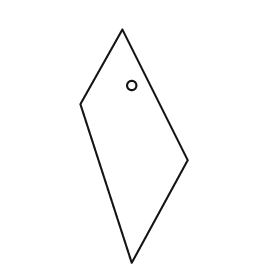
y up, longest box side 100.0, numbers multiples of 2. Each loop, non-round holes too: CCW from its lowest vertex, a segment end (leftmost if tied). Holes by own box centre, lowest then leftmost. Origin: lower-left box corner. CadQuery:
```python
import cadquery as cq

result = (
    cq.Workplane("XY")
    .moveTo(22.0, 0.0)
    .lineTo(46.0, 44.0)
    .lineTo(18.0, 100.0)
    .lineTo(0.0, 68.0)
    .close()
    .moveTo(22.0, 76.0)
    .circle(2.0)
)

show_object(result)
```